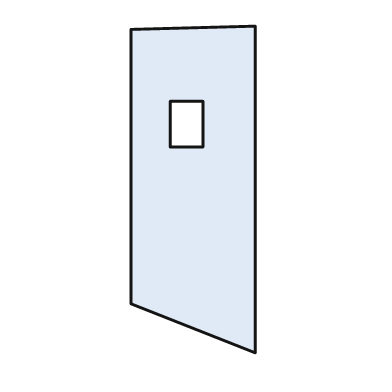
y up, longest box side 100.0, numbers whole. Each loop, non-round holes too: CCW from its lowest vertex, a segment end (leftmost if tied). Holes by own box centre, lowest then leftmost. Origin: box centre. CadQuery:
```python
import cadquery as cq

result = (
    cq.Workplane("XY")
    .moveTo(19.0, -50.0)
    .lineTo(19.0, 50.0)
    .lineTo(-19.0, 49.0)
    .lineTo(-19.0, -35.0)
    .close()
    .moveTo(-7.0, 13.0)
    .lineTo(3.0, 13.0)
    .lineTo(3.0, 27.0)
    .lineTo(-7.0, 27.0)
    .close()
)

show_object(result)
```